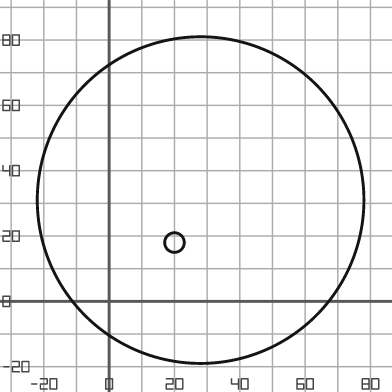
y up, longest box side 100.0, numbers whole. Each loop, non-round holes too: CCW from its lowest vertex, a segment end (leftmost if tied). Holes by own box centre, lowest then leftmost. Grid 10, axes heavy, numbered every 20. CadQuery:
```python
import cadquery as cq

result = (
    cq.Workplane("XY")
    .moveTo(28.0, 31.0)
    .circle(50.0)
    .moveTo(20.0, 18.0)
    .circle(3.0)
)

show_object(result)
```